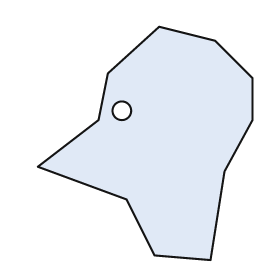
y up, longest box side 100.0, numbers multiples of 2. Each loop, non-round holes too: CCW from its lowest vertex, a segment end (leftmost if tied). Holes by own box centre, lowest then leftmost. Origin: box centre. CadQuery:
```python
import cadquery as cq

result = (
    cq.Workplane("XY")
    .moveTo(28.0, -50.0)
    .lineTo(34.0, -12.0)
    .lineTo(46.0, 10.0)
    .lineTo(46.0, 28.0)
    .lineTo(30.0, 44.0)
    .lineTo(6.0, 50.0)
    .lineTo(-16.0, 30.0)
    .lineTo(-20.0, 10.0)
    .lineTo(-46.0, -10.0)
    .lineTo(-8.0, -24.0)
    .lineTo(4.0, -48.0)
    .close()
    .moveTo(-10.0, 14.0)
    .circle(4.0)
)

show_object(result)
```